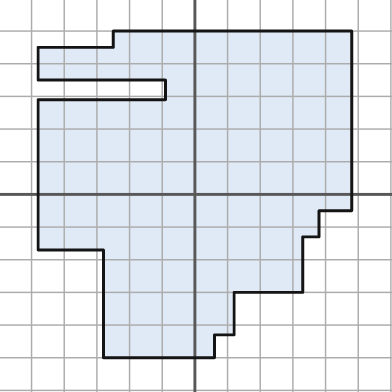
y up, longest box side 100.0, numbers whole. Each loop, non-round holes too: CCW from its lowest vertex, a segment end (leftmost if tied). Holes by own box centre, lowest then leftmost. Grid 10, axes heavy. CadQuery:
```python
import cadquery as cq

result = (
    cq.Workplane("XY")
    .moveTo(-28.0, -50.0)
    .lineTo(6.0, -50.0)
    .lineTo(6.0, -43.0)
    .lineTo(12.0, -43.0)
    .lineTo(12.0, -30.0)
    .lineTo(33.0, -30.0)
    .lineTo(33.0, -13.0)
    .lineTo(38.0, -13.0)
    .lineTo(38.0, -5.0)
    .lineTo(48.0, -5.0)
    .lineTo(48.0, 50.0)
    .lineTo(-25.0, 50.0)
    .lineTo(-25.0, 45.0)
    .lineTo(-48.0, 45.0)
    .lineTo(-48.0, 35.0)
    .lineTo(-9.0, 35.0)
    .lineTo(-9.0, 29.0)
    .lineTo(-48.0, 29.0)
    .lineTo(-48.0, -17.0)
    .lineTo(-28.0, -17.0)
    .close()
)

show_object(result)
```